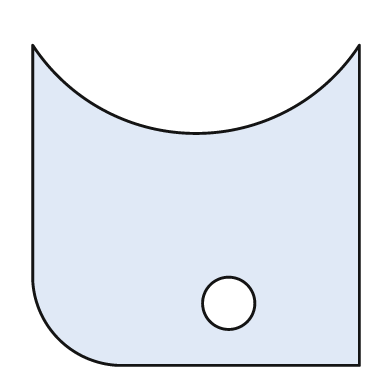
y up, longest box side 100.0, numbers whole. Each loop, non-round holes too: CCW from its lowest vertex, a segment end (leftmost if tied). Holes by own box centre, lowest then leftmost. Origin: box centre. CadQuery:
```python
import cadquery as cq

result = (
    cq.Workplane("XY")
    .moveTo(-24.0, -49.0)
    .lineTo(50.0, -49.0)
    .lineTo(50.0, 49.0)
    .threePointArc((0.0, 22.0), (-50.0, 49.0))
    .lineTo(-50.0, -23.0)
    .threePointArc((-42.0, -41.0), (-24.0, -49.0))
    .close()
    .moveTo(10.0, -30.0)
    .circle(8.0)
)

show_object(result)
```